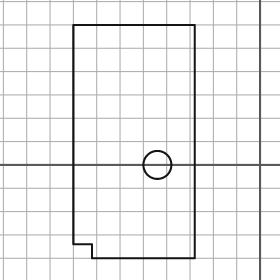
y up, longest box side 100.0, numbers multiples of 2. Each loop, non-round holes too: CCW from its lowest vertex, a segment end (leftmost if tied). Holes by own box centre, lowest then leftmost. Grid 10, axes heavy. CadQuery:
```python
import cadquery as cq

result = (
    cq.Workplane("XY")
    .moveTo(-72.0, -40.0)
    .lineTo(-28.0, -40.0)
    .lineTo(-28.0, 60.0)
    .lineTo(-80.0, 60.0)
    .lineTo(-80.0, -34.0)
    .lineTo(-72.0, -34.0)
    .close()
    .moveTo(-44.0, 0.0)
    .circle(6.0)
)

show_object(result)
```